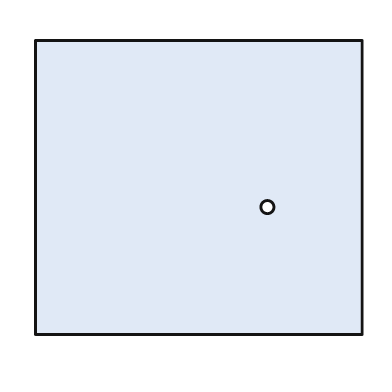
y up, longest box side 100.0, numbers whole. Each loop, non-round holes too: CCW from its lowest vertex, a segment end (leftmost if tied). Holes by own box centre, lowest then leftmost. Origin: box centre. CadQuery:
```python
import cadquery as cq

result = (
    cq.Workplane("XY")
    .moveTo(-50.0, -45.0)
    .lineTo(50.0, -45.0)
    .lineTo(50.0, 45.0)
    .lineTo(-50.0, 45.0)
    .close()
    .moveTo(21.0, -6.0)
    .circle(2.0)
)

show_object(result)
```